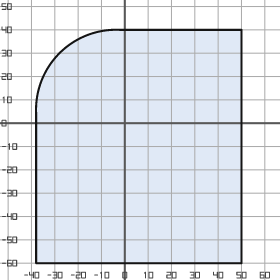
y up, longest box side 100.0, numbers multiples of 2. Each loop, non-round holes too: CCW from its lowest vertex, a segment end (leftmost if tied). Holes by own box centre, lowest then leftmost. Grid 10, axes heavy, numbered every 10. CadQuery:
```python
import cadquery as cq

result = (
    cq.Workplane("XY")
    .moveTo(-38.0, -60.0)
    .lineTo(50.0, -60.0)
    .lineTo(50.0, 40.0)
    .lineTo(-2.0, 40.0)
    .threePointArc((-28.0, 30.0), (-38.0, 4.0))
    .close()
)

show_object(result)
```